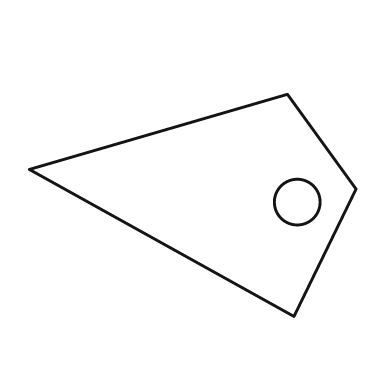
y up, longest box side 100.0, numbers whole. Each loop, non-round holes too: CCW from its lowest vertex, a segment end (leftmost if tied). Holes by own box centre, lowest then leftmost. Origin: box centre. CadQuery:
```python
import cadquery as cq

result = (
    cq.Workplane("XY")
    .moveTo(31.0, -34.0)
    .lineTo(50.0, 5.0)
    .lineTo(29.0, 34.0)
    .lineTo(-50.0, 11.0)
    .close()
    .moveTo(32.0, 1.0)
    .circle(7.0)
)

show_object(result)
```